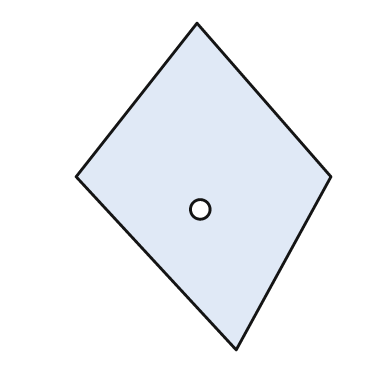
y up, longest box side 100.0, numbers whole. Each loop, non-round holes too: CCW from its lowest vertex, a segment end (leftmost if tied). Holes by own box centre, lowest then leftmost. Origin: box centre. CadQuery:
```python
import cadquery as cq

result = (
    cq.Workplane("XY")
    .moveTo(10.0, -50.0)
    .lineTo(39.0, 3.0)
    .lineTo(-2.0, 50.0)
    .lineTo(-39.0, 3.0)
    .close()
    .moveTo(-1.0, -7.0)
    .circle(3.0)
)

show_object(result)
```